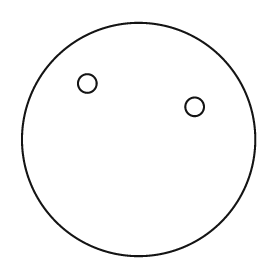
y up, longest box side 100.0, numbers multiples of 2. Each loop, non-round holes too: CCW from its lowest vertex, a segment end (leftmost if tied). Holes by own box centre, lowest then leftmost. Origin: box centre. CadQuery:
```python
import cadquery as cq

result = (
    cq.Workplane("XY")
    .moveTo(0.0, 0.0)
    .circle(50.0)
    .moveTo(24.0, 14.0)
    .circle(4.0)
    .moveTo(-22.0, 24.0)
    .circle(4.0)
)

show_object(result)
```